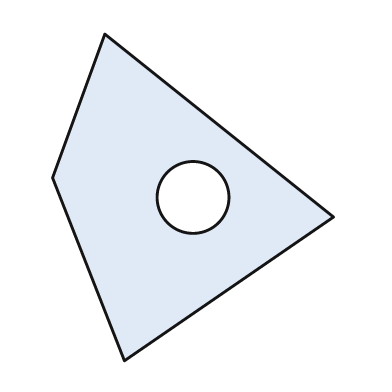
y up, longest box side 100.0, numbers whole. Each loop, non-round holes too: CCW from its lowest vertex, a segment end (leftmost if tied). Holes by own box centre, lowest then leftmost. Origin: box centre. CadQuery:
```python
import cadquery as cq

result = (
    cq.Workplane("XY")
    .moveTo(-21.0, -50.0)
    .lineTo(43.0, -6.0)
    .lineTo(-27.0, 50.0)
    .lineTo(-43.0, 6.0)
    .close()
    .moveTo(0.0, 0.0)
    .circle(11.0)
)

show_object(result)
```